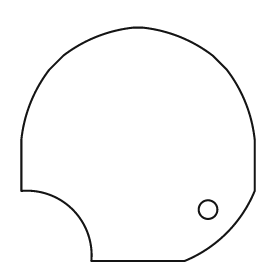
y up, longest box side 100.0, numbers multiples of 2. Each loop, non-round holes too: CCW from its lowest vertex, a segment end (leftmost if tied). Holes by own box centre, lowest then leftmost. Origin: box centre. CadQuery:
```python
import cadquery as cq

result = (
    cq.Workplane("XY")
    .moveTo(-20.0, -50.0)
    .lineTo(20.0, -50.0)
    .threePointArc((38.0, -38.0), (50.0, -20.0))
    .lineTo(50.0, 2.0)
    .threePointArc((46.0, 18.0), (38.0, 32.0))
    .lineTo(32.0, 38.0)
    .threePointArc((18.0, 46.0), (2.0, 50.0))
    .lineTo(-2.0, 50.0)
    .threePointArc((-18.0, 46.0), (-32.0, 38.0))
    .lineTo(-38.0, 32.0)
    .threePointArc((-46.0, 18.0), (-50.0, 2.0))
    .lineTo(-50.0, -20.0)
    .threePointArc((-28.0, -28.0), (-20.0, -50.0))
    .close()
    .moveTo(30.0, -28.0)
    .circle(4.0)
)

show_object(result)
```